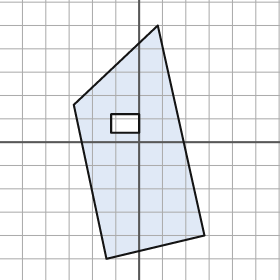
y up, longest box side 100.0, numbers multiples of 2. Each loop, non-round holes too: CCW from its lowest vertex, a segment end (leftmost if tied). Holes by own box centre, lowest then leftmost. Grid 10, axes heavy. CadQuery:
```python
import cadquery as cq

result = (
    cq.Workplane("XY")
    .moveTo(-14.0, -50.0)
    .lineTo(28.0, -40.0)
    .lineTo(8.0, 50.0)
    .lineTo(-28.0, 16.0)
    .close()
    .moveTo(-12.0, 4.0)
    .lineTo(0.0, 4.0)
    .lineTo(0.0, 12.0)
    .lineTo(-12.0, 12.0)
    .close()
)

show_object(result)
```